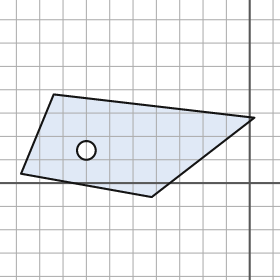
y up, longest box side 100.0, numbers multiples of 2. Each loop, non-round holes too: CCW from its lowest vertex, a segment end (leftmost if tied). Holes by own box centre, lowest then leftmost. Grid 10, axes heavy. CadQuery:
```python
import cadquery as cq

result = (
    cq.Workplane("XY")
    .moveTo(-42.0, -6.0)
    .lineTo(2.0, 28.0)
    .lineTo(-84.0, 38.0)
    .lineTo(-98.0, 4.0)
    .close()
    .moveTo(-70.0, 14.0)
    .circle(4.0)
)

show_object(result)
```